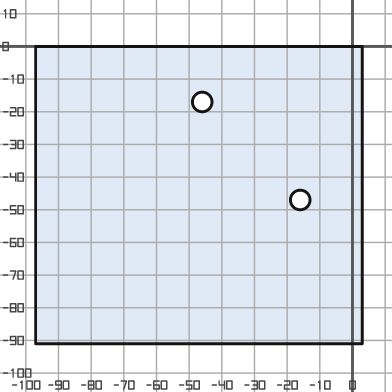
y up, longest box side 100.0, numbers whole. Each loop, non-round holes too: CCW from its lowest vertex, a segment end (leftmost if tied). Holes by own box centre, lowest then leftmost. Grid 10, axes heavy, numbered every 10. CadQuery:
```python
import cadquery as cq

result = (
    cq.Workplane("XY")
    .moveTo(-97.0, -91.0)
    .lineTo(3.0, -91.0)
    .lineTo(3.0, 0.0)
    .lineTo(-97.0, 0.0)
    .close()
    .moveTo(-16.0, -47.0)
    .circle(3.0)
    .moveTo(-46.0, -17.0)
    .circle(3.0)
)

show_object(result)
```